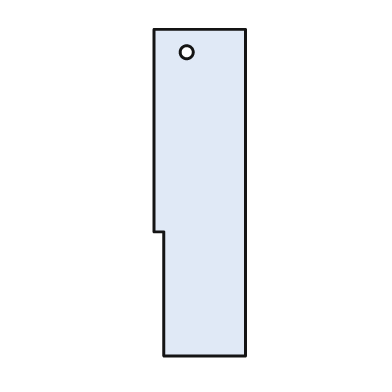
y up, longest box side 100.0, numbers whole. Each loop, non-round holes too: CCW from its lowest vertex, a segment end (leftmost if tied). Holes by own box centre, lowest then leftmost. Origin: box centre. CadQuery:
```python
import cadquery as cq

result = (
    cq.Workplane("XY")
    .moveTo(-11.0, -50.0)
    .lineTo(14.0, -50.0)
    .lineTo(14.0, 50.0)
    .lineTo(-14.0, 50.0)
    .lineTo(-14.0, -12.0)
    .lineTo(-11.0, -12.0)
    .close()
    .moveTo(-4.0, 43.0)
    .circle(2.0)
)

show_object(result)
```